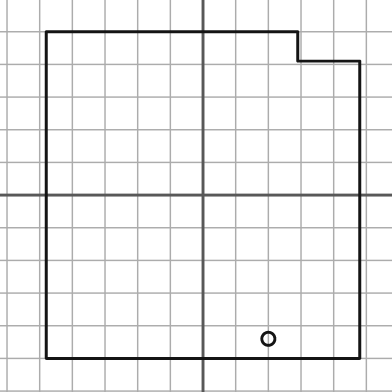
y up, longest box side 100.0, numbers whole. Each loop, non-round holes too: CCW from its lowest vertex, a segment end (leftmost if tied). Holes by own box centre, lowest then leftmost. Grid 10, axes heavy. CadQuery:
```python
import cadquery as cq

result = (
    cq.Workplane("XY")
    .moveTo(-48.0, -50.0)
    .lineTo(48.0, -50.0)
    .lineTo(48.0, 41.0)
    .lineTo(29.0, 41.0)
    .lineTo(29.0, 50.0)
    .lineTo(-48.0, 50.0)
    .close()
    .moveTo(20.0, -44.0)
    .circle(2.0)
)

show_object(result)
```